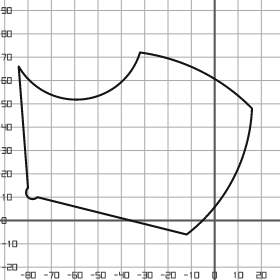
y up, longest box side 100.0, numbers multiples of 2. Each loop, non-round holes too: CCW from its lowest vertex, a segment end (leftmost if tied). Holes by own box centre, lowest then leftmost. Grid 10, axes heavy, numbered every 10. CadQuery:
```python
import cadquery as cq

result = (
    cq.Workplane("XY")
    .moveTo(-12.0, -6.0)
    .threePointArc((8.0, 18.0), (16.0, 48.0))
    .threePointArc((-6.0, 64.0), (-32.0, 72.0))
    .threePointArc((-56.0, 52.0), (-84.0, 66.0))
    .lineTo(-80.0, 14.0)
    .threePointArc((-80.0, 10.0), (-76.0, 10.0))
    .close()
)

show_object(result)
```